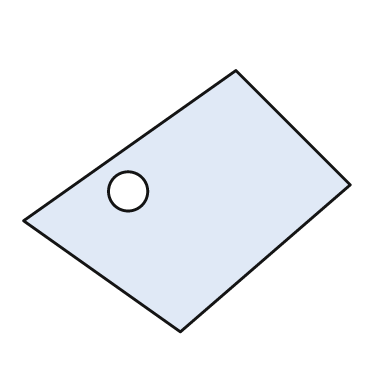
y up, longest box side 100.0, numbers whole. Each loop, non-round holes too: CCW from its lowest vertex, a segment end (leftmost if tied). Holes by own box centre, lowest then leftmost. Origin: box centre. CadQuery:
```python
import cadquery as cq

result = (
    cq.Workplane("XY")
    .moveTo(-2.0, -40.0)
    .lineTo(50.0, 5.0)
    .lineTo(15.0, 40.0)
    .lineTo(-50.0, -6.0)
    .close()
    .moveTo(-18.0, 3.0)
    .circle(6.0)
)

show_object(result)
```